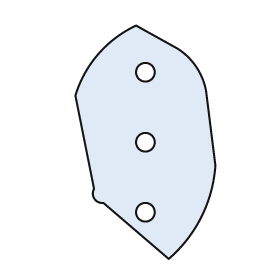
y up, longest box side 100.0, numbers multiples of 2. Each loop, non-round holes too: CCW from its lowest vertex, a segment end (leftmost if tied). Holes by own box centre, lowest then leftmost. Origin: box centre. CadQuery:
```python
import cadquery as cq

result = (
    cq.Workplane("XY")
    .moveTo(10.0, -50.0)
    .threePointArc((24.0, -32.0), (30.0, -10.0))
    .lineTo(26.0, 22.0)
    .threePointArc((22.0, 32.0), (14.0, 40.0))
    .lineTo(-4.0, 50.0)
    .threePointArc((-20.0, 38.0), (-30.0, 20.0))
    .lineTo(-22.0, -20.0)
    .threePointArc((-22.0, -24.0), (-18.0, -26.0))
    .close()
    .moveTo(0.0, -30.0)
    .circle(4.0)
    .moveTo(0.0, 0.0)
    .circle(4.0)
    .moveTo(0.0, 30.0)
    .circle(4.0)
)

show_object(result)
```